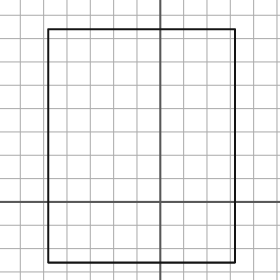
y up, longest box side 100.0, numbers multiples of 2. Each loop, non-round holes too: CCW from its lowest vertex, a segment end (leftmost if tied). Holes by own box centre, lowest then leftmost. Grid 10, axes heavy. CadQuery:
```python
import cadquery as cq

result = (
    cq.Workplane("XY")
    .moveTo(-48.0, -26.0)
    .lineTo(32.0, -26.0)
    .lineTo(32.0, 74.0)
    .lineTo(-48.0, 74.0)
    .close()
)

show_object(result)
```